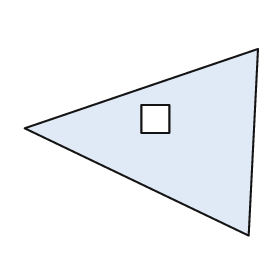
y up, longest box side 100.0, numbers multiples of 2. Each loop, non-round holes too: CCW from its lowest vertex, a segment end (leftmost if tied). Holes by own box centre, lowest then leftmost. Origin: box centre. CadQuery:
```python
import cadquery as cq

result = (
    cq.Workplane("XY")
    .moveTo(46.0, -40.0)
    .lineTo(50.0, 40.0)
    .lineTo(-50.0, 6.0)
    .close()
    .moveTo(0.0, 4.0)
    .lineTo(12.0, 4.0)
    .lineTo(12.0, 16.0)
    .lineTo(0.0, 16.0)
    .close()
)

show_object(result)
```